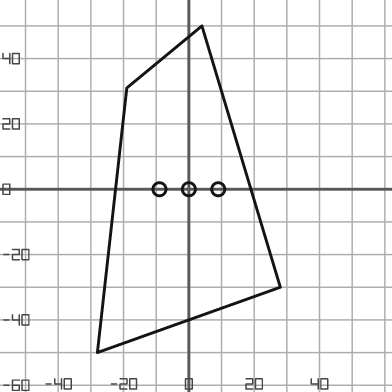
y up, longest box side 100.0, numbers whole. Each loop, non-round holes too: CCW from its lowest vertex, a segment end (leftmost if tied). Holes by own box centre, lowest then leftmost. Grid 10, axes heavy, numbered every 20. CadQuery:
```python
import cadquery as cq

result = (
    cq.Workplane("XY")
    .moveTo(-28.0, -50.0)
    .lineTo(28.0, -30.0)
    .lineTo(4.0, 50.0)
    .lineTo(-19.0, 31.0)
    .close()
    .moveTo(-9.0, 0.0)
    .circle(2.0)
    .moveTo(0.0, 0.0)
    .circle(2.0)
    .moveTo(9.0, 0.0)
    .circle(2.0)
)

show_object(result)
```